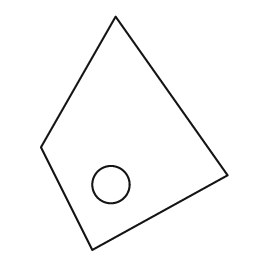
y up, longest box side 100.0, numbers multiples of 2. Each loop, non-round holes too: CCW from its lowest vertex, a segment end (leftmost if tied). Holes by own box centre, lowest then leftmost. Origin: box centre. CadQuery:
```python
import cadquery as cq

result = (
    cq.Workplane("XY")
    .moveTo(-18.0, -50.0)
    .lineTo(40.0, -18.0)
    .lineTo(-8.0, 50.0)
    .lineTo(-40.0, -6.0)
    .close()
    .moveTo(-10.0, -22.0)
    .circle(8.0)
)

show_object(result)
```